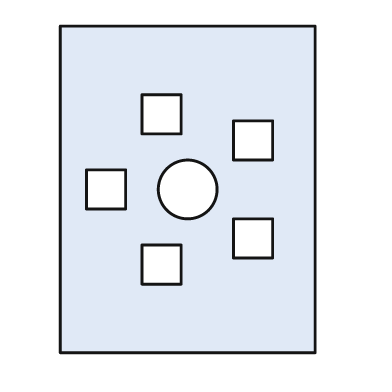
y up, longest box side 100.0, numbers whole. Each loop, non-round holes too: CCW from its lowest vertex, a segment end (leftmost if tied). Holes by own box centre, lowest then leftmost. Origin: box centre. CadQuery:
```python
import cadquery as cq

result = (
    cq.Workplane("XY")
    .moveTo(-39.0, -50.0)
    .lineTo(39.0, -50.0)
    .lineTo(39.0, 50.0)
    .lineTo(-39.0, 50.0)
    .close()
    .moveTo(-14.0, -29.0)
    .lineTo(-2.0, -29.0)
    .lineTo(-2.0, -17.0)
    .lineTo(-14.0, -17.0)
    .close()
    .moveTo(14.0, -21.0)
    .lineTo(26.0, -21.0)
    .lineTo(26.0, -9.0)
    .lineTo(14.0, -9.0)
    .close()
    .moveTo(-31.0, -6.0)
    .lineTo(-19.0, -6.0)
    .lineTo(-19.0, 6.0)
    .lineTo(-31.0, 6.0)
    .close()
    .moveTo(0.0, 0.0)
    .circle(9.0)
    .moveTo(14.0, 9.0)
    .lineTo(26.0, 9.0)
    .lineTo(26.0, 21.0)
    .lineTo(14.0, 21.0)
    .close()
    .moveTo(-14.0, 17.0)
    .lineTo(-2.0, 17.0)
    .lineTo(-2.0, 29.0)
    .lineTo(-14.0, 29.0)
    .close()
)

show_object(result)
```